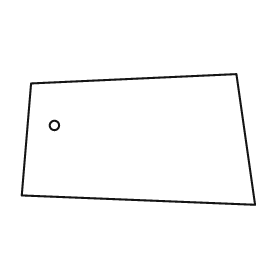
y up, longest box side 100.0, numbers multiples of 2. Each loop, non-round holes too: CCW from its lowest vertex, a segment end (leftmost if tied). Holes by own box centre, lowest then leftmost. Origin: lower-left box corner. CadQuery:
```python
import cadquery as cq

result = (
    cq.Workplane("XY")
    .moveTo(100.0, 0.0)
    .lineTo(92.0, 56.0)
    .lineTo(4.0, 52.0)
    .lineTo(0.0, 4.0)
    .close()
    .moveTo(14.0, 34.0)
    .circle(2.0)
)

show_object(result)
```